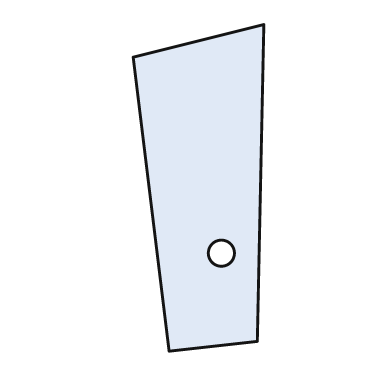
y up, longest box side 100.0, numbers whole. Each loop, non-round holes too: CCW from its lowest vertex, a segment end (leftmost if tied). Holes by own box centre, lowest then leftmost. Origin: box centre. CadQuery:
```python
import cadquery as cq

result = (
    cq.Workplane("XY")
    .moveTo(-9.0, -50.0)
    .lineTo(18.0, -47.0)
    .lineTo(20.0, 50.0)
    .lineTo(-20.0, 40.0)
    .close()
    .moveTo(7.0, -20.0)
    .circle(4.0)
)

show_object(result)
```